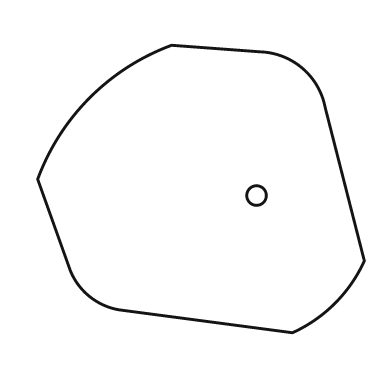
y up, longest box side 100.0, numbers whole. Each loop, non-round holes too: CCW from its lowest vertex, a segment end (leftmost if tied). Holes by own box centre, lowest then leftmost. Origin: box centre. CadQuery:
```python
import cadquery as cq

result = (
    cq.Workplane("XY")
    .moveTo(28.0, -44.0)
    .threePointArc((41.0, -35.0), (50.0, -22.0))
    .lineTo(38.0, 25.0)
    .threePointArc((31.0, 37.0), (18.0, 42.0))
    .lineTo(-9.0, 44.0)
    .threePointArc((-34.0, 28.0), (-50.0, 3.0))
    .lineTo(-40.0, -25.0)
    .threePointArc((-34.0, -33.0), (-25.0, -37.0))
    .close()
    .moveTo(17.0, -2.0)
    .circle(3.0)
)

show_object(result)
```